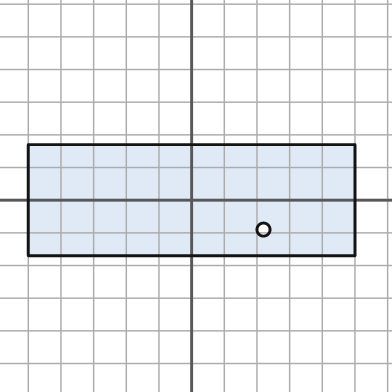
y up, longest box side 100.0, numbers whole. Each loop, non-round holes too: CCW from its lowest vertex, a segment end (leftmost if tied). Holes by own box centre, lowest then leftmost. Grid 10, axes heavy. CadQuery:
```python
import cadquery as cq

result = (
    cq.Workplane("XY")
    .moveTo(-50.0, -17.0)
    .lineTo(50.0, -17.0)
    .lineTo(50.0, 17.0)
    .lineTo(-50.0, 17.0)
    .close()
    .moveTo(22.0, -9.0)
    .circle(2.0)
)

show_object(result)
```